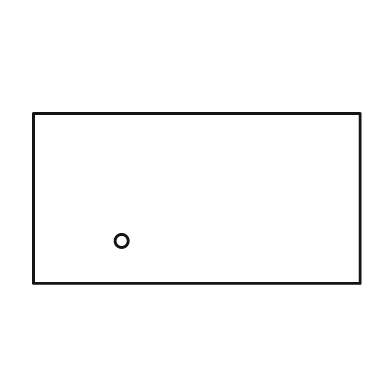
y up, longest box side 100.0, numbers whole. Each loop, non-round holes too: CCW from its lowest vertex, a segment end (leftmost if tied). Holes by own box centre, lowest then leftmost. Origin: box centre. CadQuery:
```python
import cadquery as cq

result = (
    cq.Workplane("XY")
    .moveTo(-50.0, -26.0)
    .lineTo(50.0, -26.0)
    .lineTo(50.0, 26.0)
    .lineTo(-50.0, 26.0)
    .close()
    .moveTo(-23.0, -13.0)
    .circle(2.0)
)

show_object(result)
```